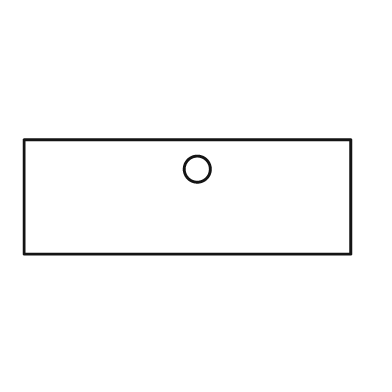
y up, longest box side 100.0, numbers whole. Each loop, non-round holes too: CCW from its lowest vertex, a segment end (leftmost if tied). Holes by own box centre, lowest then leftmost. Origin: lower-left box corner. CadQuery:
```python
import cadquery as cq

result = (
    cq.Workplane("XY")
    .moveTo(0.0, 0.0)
    .lineTo(100.0, 0.0)
    .lineTo(100.0, 35.0)
    .lineTo(0.0, 35.0)
    .close()
    .moveTo(53.0, 26.0)
    .circle(4.0)
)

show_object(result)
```